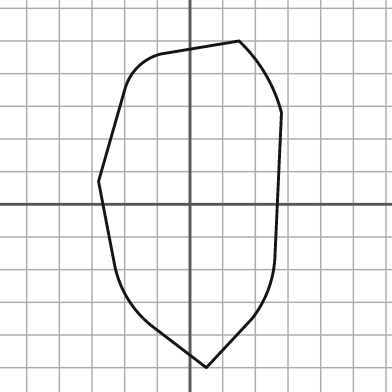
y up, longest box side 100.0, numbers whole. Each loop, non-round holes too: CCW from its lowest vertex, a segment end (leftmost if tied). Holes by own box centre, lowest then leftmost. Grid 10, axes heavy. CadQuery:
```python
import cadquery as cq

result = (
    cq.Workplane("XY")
    .moveTo(5.0, -50.0)
    .lineTo(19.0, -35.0)
    .threePointArc((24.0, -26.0), (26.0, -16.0))
    .lineTo(28.0, 28.0)
    .threePointArc((23.0, 40.0), (15.0, 50.0))
    .lineTo(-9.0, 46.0)
    .threePointArc((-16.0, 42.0), (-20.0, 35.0))
    .lineTo(-28.0, 7.0)
    .lineTo(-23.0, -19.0)
    .threePointArc((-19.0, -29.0), (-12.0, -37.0))
    .close()
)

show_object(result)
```